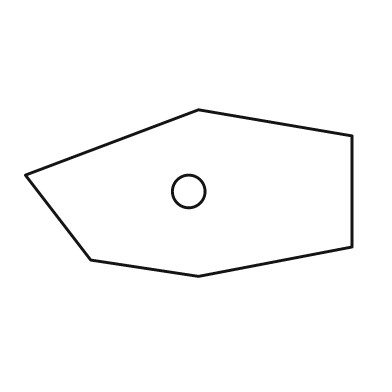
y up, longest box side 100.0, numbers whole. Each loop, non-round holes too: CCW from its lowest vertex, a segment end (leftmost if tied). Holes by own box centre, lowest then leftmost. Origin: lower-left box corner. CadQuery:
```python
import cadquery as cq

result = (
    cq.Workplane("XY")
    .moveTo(53.0, 0.0)
    .lineTo(100.0, 9.0)
    .lineTo(100.0, 43.0)
    .lineTo(53.0, 51.0)
    .lineTo(0.0, 31.0)
    .lineTo(20.0, 5.0)
    .close()
    .moveTo(50.0, 26.0)
    .circle(5.0)
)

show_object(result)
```